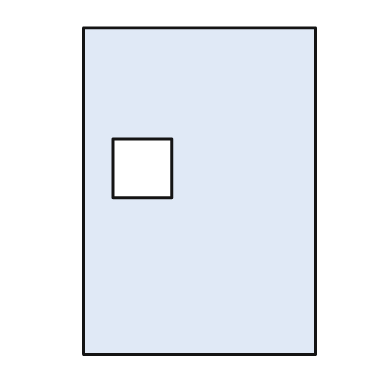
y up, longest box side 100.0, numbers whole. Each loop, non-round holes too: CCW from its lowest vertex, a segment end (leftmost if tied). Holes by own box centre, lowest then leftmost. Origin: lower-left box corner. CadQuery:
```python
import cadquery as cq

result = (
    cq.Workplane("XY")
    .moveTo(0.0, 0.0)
    .lineTo(71.0, 0.0)
    .lineTo(71.0, 100.0)
    .lineTo(0.0, 100.0)
    .close()
    .moveTo(9.0, 48.0)
    .lineTo(27.0, 48.0)
    .lineTo(27.0, 66.0)
    .lineTo(9.0, 66.0)
    .close()
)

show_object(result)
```